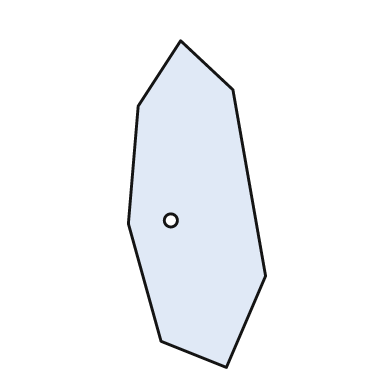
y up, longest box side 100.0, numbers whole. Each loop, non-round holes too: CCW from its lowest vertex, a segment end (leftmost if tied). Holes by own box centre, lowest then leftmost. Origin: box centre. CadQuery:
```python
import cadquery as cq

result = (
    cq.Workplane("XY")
    .moveTo(9.0, -50.0)
    .lineTo(21.0, -22.0)
    .lineTo(11.0, 35.0)
    .lineTo(-5.0, 50.0)
    .lineTo(-18.0, 30.0)
    .lineTo(-21.0, -6.0)
    .lineTo(-11.0, -42.0)
    .close()
    .moveTo(-8.0, -5.0)
    .circle(2.0)
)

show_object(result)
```